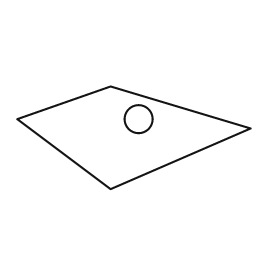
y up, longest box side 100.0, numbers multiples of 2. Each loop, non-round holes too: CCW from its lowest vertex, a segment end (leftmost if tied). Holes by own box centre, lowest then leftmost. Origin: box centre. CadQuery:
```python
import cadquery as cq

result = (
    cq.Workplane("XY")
    .moveTo(-10.0, -22.0)
    .lineTo(50.0, 4.0)
    .lineTo(-10.0, 22.0)
    .lineTo(-50.0, 8.0)
    .close()
    .moveTo(2.0, 8.0)
    .circle(6.0)
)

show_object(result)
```